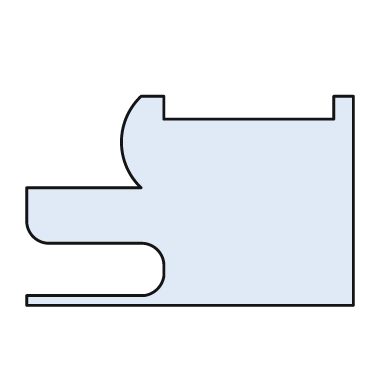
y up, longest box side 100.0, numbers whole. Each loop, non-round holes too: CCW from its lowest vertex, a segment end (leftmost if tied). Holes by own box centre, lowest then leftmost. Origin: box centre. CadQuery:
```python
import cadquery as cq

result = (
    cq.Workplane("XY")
    .moveTo(-50.0, -32.0)
    .lineTo(50.0, -32.0)
    .lineTo(50.0, 32.0)
    .lineTo(44.0, 32.0)
    .lineTo(44.0, 25.0)
    .lineTo(-8.0, 25.0)
    .lineTo(-8.0, 32.0)
    .lineTo(-15.0, 32.0)
    .threePointArc((-21.0, 18.0), (-15.0, 4.0))
    .lineTo(-50.0, 4.0)
    .lineTo(-50.0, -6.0)
    .threePointArc((-48.0, -11.0), (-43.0, -13.0))
    .lineTo(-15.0, -13.0)
    .threePointArc((-10.0, -15.0), (-8.0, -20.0))
    .lineTo(-8.0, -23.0)
    .threePointArc((-10.0, -27.0), (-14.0, -29.0))
    .lineTo(-50.0, -29.0)
    .close()
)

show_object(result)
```